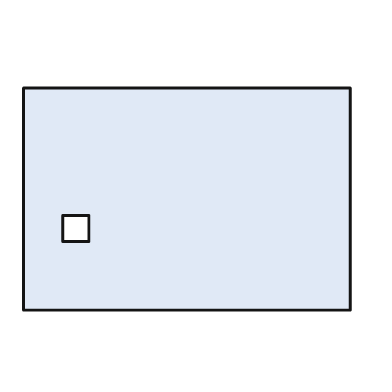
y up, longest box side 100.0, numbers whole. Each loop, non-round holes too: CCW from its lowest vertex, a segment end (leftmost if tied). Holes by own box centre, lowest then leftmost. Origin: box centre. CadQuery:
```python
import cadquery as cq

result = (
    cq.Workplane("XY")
    .moveTo(-50.0, -34.0)
    .lineTo(50.0, -34.0)
    .lineTo(50.0, 34.0)
    .lineTo(-50.0, 34.0)
    .close()
    .moveTo(-38.0, -13.0)
    .lineTo(-30.0, -13.0)
    .lineTo(-30.0, -5.0)
    .lineTo(-38.0, -5.0)
    .close()
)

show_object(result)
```